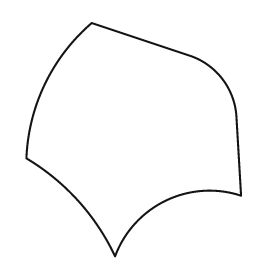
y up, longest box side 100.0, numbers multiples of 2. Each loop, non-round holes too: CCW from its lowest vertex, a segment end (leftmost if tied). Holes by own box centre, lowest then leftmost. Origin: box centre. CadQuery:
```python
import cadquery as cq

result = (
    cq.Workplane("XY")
    .moveTo(-8.0, -50.0)
    .threePointArc((14.0, -26.0), (46.0, -24.0))
    .lineTo(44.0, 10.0)
    .threePointArc((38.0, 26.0), (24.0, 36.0))
    .lineTo(-18.0, 50.0)
    .threePointArc((-38.0, 24.0), (-46.0, -8.0))
    .threePointArc((-24.0, -26.0), (-8.0, -50.0))
    .close()
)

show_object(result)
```